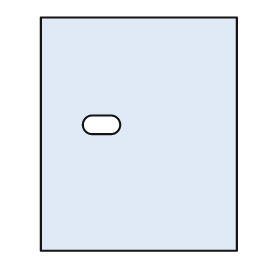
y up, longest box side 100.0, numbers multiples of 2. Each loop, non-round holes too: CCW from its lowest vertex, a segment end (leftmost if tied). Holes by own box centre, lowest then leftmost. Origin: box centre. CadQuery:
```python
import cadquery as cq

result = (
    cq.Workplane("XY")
    .moveTo(-42.0, -50.0)
    .lineTo(42.0, -50.0)
    .lineTo(42.0, 50.0)
    .lineTo(-42.0, 50.0)
    .close()
    .moveTo(-20.0, 0.0)
    .lineTo(-12.0, 0.0)
    .threePointArc((-8.0, 4.0), (-12.0, 8.0))
    .lineTo(-20.0, 8.0)
    .threePointArc((-24.0, 4.0), (-20.0, 0.0))
    .close()
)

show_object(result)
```